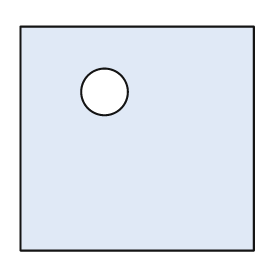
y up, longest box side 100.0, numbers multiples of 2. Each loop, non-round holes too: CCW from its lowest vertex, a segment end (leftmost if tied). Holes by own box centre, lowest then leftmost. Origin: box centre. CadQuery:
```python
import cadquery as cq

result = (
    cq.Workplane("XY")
    .moveTo(-50.0, -48.0)
    .lineTo(50.0, -48.0)
    .lineTo(50.0, 48.0)
    .lineTo(-50.0, 48.0)
    .close()
    .moveTo(-14.0, 20.0)
    .circle(10.0)
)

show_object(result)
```